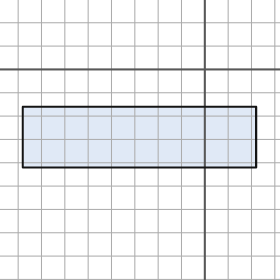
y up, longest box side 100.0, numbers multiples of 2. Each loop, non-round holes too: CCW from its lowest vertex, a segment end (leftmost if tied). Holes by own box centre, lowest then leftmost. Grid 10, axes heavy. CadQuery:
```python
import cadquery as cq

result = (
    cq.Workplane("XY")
    .moveTo(-78.0, -42.0)
    .lineTo(22.0, -42.0)
    .lineTo(22.0, -16.0)
    .lineTo(-78.0, -16.0)
    .close()
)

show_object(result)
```